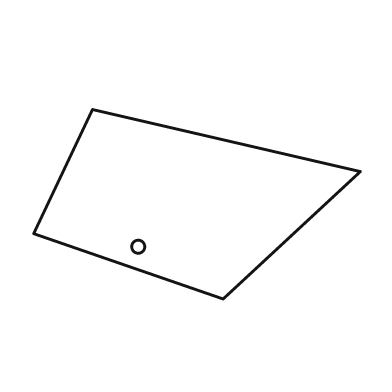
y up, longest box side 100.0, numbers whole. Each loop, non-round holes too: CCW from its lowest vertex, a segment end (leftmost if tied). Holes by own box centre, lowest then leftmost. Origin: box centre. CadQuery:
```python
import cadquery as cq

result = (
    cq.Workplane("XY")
    .moveTo(8.0, -29.0)
    .lineTo(50.0, 10.0)
    .lineTo(-32.0, 29.0)
    .lineTo(-50.0, -9.0)
    .close()
    .moveTo(-18.0, -13.0)
    .circle(2.0)
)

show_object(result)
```